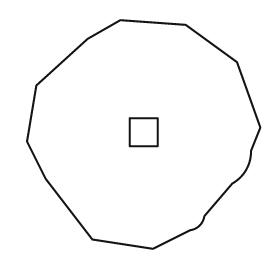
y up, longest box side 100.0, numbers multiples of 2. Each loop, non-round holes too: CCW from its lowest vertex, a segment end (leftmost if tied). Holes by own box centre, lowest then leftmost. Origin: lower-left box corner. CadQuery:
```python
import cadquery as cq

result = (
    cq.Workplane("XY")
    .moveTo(54.0, 0.0)
    .lineTo(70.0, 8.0)
    .threePointArc((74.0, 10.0), (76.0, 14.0))
    .lineTo(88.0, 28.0)
    .threePointArc((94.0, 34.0), (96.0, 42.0))
    .lineTo(100.0, 52.0)
    .lineTo(90.0, 80.0)
    .lineTo(68.0, 96.0)
    .lineTo(40.0, 98.0)
    .lineTo(26.0, 90.0)
    .lineTo(4.0, 70.0)
    .lineTo(0.0, 46.0)
    .lineTo(8.0, 30.0)
    .lineTo(28.0, 4.0)
    .close()
    .moveTo(44.0, 44.0)
    .lineTo(56.0, 44.0)
    .lineTo(56.0, 56.0)
    .lineTo(44.0, 56.0)
    .close()
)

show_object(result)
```